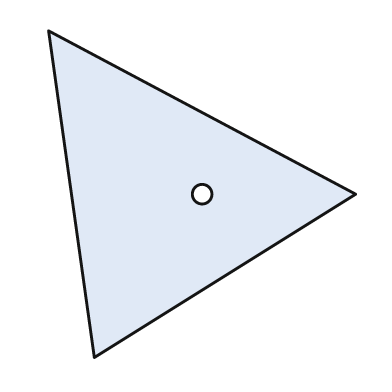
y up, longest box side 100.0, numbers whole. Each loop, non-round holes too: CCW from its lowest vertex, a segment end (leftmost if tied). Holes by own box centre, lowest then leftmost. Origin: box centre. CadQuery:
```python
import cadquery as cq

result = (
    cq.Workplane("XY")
    .moveTo(-33.0, -50.0)
    .lineTo(47.0, 0.0)
    .lineTo(-47.0, 50.0)
    .close()
    .moveTo(0.0, 0.0)
    .circle(3.0)
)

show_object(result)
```